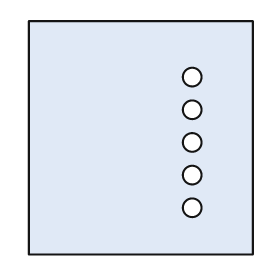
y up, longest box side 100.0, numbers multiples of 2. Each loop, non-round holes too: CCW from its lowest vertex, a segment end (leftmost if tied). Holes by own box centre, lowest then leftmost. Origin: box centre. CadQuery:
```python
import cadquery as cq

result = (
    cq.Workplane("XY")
    .moveTo(-48.0, -50.0)
    .lineTo(48.0, -50.0)
    .lineTo(48.0, 50.0)
    .lineTo(-48.0, 50.0)
    .close()
    .moveTo(22.0, -30.0)
    .circle(4.0)
    .moveTo(22.0, -16.0)
    .circle(4.0)
    .moveTo(22.0, -2.0)
    .circle(4.0)
    .moveTo(22.0, 12.0)
    .circle(4.0)
    .moveTo(22.0, 26.0)
    .circle(4.0)
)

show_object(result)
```